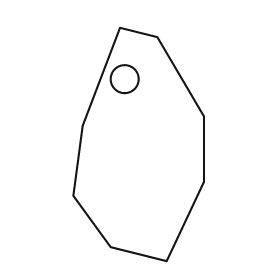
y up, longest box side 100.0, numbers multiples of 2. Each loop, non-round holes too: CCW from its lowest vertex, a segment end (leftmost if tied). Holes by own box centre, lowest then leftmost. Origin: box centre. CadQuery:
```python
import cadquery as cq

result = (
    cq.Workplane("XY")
    .moveTo(12.0, -50.0)
    .lineTo(28.0, -16.0)
    .lineTo(28.0, 12.0)
    .lineTo(8.0, 46.0)
    .lineTo(-8.0, 50.0)
    .lineTo(-24.0, 8.0)
    .lineTo(-28.0, -22.0)
    .lineTo(-12.0, -44.0)
    .close()
    .moveTo(-6.0, 28.0)
    .circle(6.0)
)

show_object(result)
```